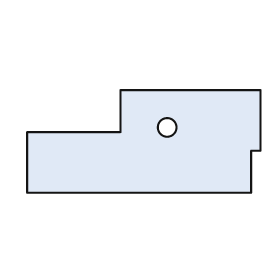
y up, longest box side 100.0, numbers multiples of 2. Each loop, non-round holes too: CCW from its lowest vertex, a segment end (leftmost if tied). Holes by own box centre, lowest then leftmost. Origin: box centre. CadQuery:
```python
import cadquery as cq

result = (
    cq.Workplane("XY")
    .moveTo(-50.0, -22.0)
    .lineTo(46.0, -22.0)
    .lineTo(46.0, -4.0)
    .lineTo(50.0, -4.0)
    .lineTo(50.0, 22.0)
    .lineTo(-10.0, 22.0)
    .lineTo(-10.0, 4.0)
    .lineTo(-50.0, 4.0)
    .close()
    .moveTo(10.0, 6.0)
    .circle(4.0)
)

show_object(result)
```